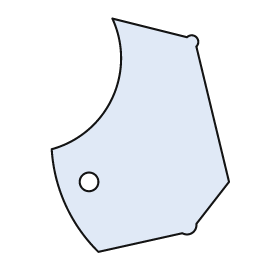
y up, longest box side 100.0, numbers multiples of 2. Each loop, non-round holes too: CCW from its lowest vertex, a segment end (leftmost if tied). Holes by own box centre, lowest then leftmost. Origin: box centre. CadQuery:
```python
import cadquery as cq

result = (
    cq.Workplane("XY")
    .moveTo(-18.0, -50.0)
    .lineTo(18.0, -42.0)
    .threePointArc((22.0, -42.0), (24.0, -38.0))
    .lineTo(38.0, -20.0)
    .lineTo(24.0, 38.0)
    .threePointArc((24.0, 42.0), (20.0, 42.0))
    .lineTo(-12.0, 50.0)
    .threePointArc((-12.0, 16.0), (-38.0, -6.0))
    .threePointArc((-32.0, -30.0), (-18.0, -50.0))
    .close()
    .moveTo(-22.0, -20.0)
    .circle(4.0)
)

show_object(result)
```